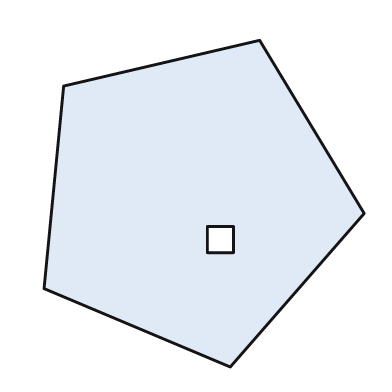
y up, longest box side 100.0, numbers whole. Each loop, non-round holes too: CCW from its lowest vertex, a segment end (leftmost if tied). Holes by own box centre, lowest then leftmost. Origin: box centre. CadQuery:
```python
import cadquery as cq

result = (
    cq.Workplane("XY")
    .moveTo(8.0, -50.0)
    .lineTo(49.0, -3.0)
    .lineTo(17.0, 50.0)
    .lineTo(-43.0, 36.0)
    .lineTo(-49.0, -26.0)
    .close()
    .moveTo(1.0, -15.0)
    .lineTo(9.0, -15.0)
    .lineTo(9.0, -7.0)
    .lineTo(1.0, -7.0)
    .close()
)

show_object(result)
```